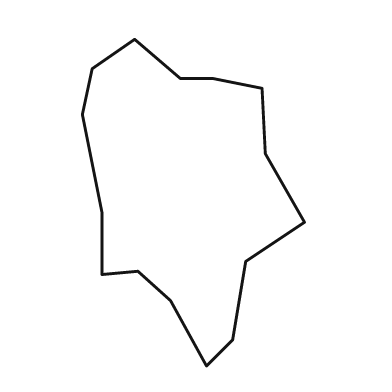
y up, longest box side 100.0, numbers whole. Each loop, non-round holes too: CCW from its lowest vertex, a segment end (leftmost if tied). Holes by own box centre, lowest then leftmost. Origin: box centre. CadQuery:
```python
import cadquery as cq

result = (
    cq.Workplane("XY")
    .moveTo(4.0, -50.0)
    .lineTo(12.0, -42.0)
    .lineTo(16.0, -18.0)
    .lineTo(34.0, -6.0)
    .lineTo(22.0, 15.0)
    .lineTo(21.0, 35.0)
    .lineTo(6.0, 38.0)
    .lineTo(-4.0, 38.0)
    .lineTo(-18.0, 50.0)
    .lineTo(-31.0, 41.0)
    .lineTo(-34.0, 27.0)
    .lineTo(-28.0, -3.0)
    .lineTo(-28.0, -22.0)
    .lineTo(-17.0, -21.0)
    .lineTo(-7.0, -30.0)
    .close()
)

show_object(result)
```